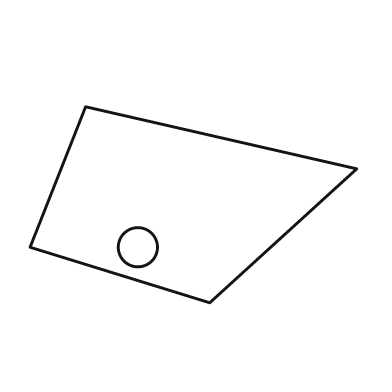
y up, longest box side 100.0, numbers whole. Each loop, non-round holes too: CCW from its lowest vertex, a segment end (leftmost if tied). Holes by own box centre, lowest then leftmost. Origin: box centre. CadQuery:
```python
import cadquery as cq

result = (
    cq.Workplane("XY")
    .moveTo(5.0, -30.0)
    .lineTo(50.0, 11.0)
    .lineTo(-33.0, 30.0)
    .lineTo(-50.0, -13.0)
    .close()
    .moveTo(-17.0, -13.0)
    .circle(6.0)
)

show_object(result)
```